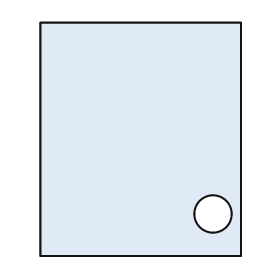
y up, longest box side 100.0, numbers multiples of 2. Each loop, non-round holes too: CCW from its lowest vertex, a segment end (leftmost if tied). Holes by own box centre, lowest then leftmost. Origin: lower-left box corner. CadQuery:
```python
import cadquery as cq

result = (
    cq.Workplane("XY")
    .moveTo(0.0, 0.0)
    .lineTo(86.0, 0.0)
    .lineTo(86.0, 100.0)
    .lineTo(0.0, 100.0)
    .close()
    .moveTo(74.0, 18.0)
    .circle(8.0)
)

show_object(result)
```